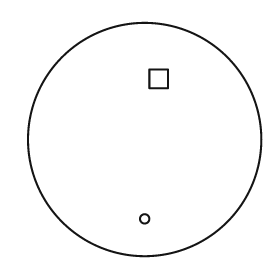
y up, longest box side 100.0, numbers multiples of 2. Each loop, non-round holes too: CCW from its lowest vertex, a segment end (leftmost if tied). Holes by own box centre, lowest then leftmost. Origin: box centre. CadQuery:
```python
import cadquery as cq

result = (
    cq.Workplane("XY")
    .moveTo(0.0, 0.0)
    .circle(50.0)
    .moveTo(0.0, -34.0)
    .circle(2.0)
    .moveTo(2.0, 22.0)
    .lineTo(10.0, 22.0)
    .lineTo(10.0, 30.0)
    .lineTo(2.0, 30.0)
    .close()
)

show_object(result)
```